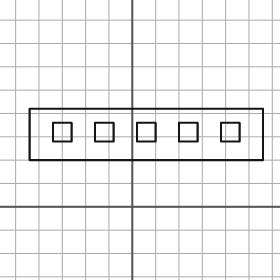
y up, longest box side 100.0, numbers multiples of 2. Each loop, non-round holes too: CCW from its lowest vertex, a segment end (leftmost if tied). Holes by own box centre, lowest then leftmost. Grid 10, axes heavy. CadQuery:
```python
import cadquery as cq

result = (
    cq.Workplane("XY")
    .moveTo(-44.0, 20.0)
    .lineTo(56.0, 20.0)
    .lineTo(56.0, 42.0)
    .lineTo(-44.0, 42.0)
    .close()
    .moveTo(-34.0, 28.0)
    .lineTo(-26.0, 28.0)
    .lineTo(-26.0, 36.0)
    .lineTo(-34.0, 36.0)
    .close()
    .moveTo(-16.0, 28.0)
    .lineTo(-8.0, 28.0)
    .lineTo(-8.0, 36.0)
    .lineTo(-16.0, 36.0)
    .close()
    .moveTo(2.0, 28.0)
    .lineTo(10.0, 28.0)
    .lineTo(10.0, 36.0)
    .lineTo(2.0, 36.0)
    .close()
    .moveTo(20.0, 28.0)
    .lineTo(28.0, 28.0)
    .lineTo(28.0, 36.0)
    .lineTo(20.0, 36.0)
    .close()
    .moveTo(38.0, 28.0)
    .lineTo(46.0, 28.0)
    .lineTo(46.0, 36.0)
    .lineTo(38.0, 36.0)
    .close()
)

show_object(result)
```